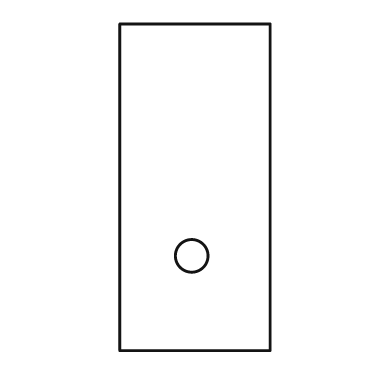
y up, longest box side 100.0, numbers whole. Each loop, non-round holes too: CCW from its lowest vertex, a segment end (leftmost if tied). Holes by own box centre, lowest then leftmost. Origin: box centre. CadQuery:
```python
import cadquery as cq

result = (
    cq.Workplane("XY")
    .moveTo(-23.0, -50.0)
    .lineTo(23.0, -50.0)
    .lineTo(23.0, 50.0)
    .lineTo(-23.0, 50.0)
    .close()
    .moveTo(-1.0, -21.0)
    .circle(5.0)
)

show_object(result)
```